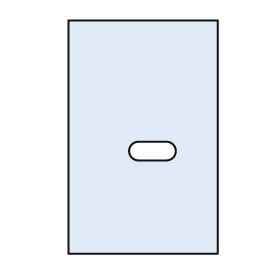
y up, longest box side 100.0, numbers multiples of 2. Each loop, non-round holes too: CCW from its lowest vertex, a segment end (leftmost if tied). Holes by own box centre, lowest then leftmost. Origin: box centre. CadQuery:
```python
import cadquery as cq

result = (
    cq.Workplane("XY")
    .moveTo(-32.0, -50.0)
    .lineTo(32.0, -50.0)
    .lineTo(32.0, 50.0)
    .lineTo(-32.0, 50.0)
    .close()
    .moveTo(-2.0, -10.0)
    .lineTo(10.0, -10.0)
    .threePointArc((14.0, -6.0), (10.0, -2.0))
    .lineTo(-2.0, -2.0)
    .threePointArc((-6.0, -6.0), (-2.0, -10.0))
    .close()
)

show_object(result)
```